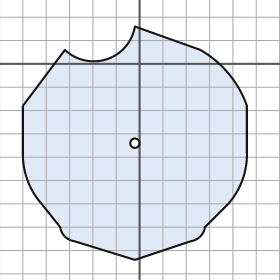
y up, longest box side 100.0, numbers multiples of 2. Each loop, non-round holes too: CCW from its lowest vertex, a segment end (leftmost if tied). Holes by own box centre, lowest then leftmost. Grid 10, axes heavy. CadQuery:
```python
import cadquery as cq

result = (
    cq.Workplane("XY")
    .moveTo(-2.0, -84.0)
    .lineTo(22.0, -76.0)
    .threePointArc((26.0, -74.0), (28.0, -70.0))
    .lineTo(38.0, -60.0)
    .threePointArc((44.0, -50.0), (46.0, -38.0))
    .lineTo(46.0, -18.0)
    .threePointArc((38.0, -4.0), (26.0, 6.0))
    .lineTo(-2.0, 16.0)
    .threePointArc((-14.0, 2.0), (-32.0, 6.0))
    .lineTo(-50.0, -18.0)
    .lineTo(-50.0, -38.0)
    .threePointArc((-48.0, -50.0), (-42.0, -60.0))
    .lineTo(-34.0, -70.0)
    .threePointArc((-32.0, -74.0), (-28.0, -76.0))
    .close()
    .moveTo(-2.0, -34.0)
    .circle(2.0)
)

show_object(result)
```